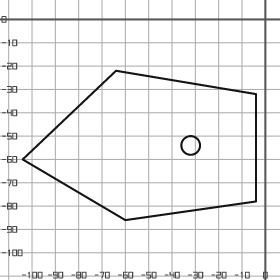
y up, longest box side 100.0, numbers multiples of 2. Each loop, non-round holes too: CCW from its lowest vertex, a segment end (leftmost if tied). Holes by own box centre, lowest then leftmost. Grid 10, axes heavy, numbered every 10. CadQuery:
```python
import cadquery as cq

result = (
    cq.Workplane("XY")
    .moveTo(-60.0, -86.0)
    .lineTo(-4.0, -78.0)
    .lineTo(-4.0, -32.0)
    .lineTo(-64.0, -22.0)
    .lineTo(-104.0, -60.0)
    .close()
    .moveTo(-32.0, -54.0)
    .circle(4.0)
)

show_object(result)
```